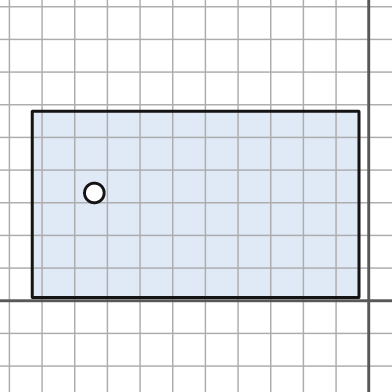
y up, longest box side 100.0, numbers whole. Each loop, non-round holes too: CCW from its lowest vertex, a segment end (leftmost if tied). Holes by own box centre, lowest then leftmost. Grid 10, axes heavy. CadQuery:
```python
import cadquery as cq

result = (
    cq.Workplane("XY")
    .moveTo(-103.0, 1.0)
    .lineTo(-3.0, 1.0)
    .lineTo(-3.0, 58.0)
    .lineTo(-103.0, 58.0)
    .close()
    .moveTo(-84.0, 33.0)
    .circle(3.0)
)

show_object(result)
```